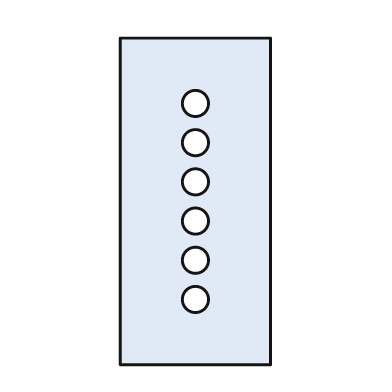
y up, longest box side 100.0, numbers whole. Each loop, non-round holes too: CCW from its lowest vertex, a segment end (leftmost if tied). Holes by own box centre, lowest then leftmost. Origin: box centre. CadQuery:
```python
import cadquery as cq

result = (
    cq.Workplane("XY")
    .moveTo(-23.0, -50.0)
    .lineTo(23.0, -50.0)
    .lineTo(23.0, 50.0)
    .lineTo(-23.0, 50.0)
    .close()
    .moveTo(0.0, -30.0)
    .circle(4.0)
    .moveTo(0.0, -18.0)
    .circle(4.0)
    .moveTo(0.0, -6.0)
    .circle(4.0)
    .moveTo(0.0, 6.0)
    .circle(4.0)
    .moveTo(0.0, 18.0)
    .circle(4.0)
    .moveTo(0.0, 30.0)
    .circle(4.0)
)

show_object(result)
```